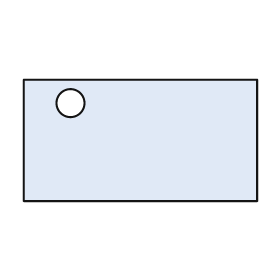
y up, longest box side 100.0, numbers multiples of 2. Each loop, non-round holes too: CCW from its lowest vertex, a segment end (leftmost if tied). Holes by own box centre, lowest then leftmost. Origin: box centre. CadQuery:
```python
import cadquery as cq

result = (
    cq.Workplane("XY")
    .moveTo(-50.0, -26.0)
    .lineTo(50.0, -26.0)
    .lineTo(50.0, 26.0)
    .lineTo(-50.0, 26.0)
    .close()
    .moveTo(-30.0, 16.0)
    .circle(6.0)
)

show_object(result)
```